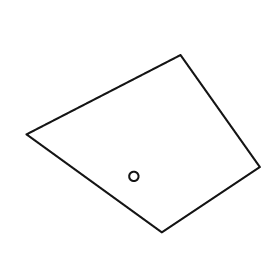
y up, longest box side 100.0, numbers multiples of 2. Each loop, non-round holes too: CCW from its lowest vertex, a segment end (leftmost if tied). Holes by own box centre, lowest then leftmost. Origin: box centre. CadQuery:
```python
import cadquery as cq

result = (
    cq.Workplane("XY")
    .moveTo(8.0, -38.0)
    .lineTo(50.0, -10.0)
    .lineTo(16.0, 38.0)
    .lineTo(-50.0, 4.0)
    .close()
    .moveTo(-4.0, -14.0)
    .circle(2.0)
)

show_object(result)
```